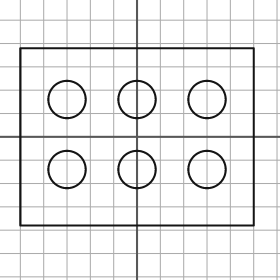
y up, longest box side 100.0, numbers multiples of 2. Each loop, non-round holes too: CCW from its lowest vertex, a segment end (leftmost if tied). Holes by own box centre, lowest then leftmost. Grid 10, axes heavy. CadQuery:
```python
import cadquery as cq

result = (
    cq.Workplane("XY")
    .moveTo(-50.0, -38.0)
    .lineTo(50.0, -38.0)
    .lineTo(50.0, 38.0)
    .lineTo(-50.0, 38.0)
    .close()
    .moveTo(-30.0, -14.0)
    .circle(8.0)
    .moveTo(0.0, -14.0)
    .circle(8.0)
    .moveTo(30.0, -14.0)
    .circle(8.0)
    .moveTo(-30.0, 16.0)
    .circle(8.0)
    .moveTo(0.0, 16.0)
    .circle(8.0)
    .moveTo(30.0, 16.0)
    .circle(8.0)
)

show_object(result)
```